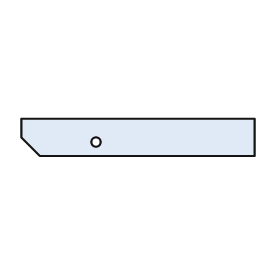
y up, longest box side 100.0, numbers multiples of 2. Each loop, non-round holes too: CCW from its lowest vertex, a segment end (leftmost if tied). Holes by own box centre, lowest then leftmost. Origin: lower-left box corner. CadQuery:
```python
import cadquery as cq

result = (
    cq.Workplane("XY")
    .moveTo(8.0, 0.0)
    .lineTo(100.0, 0.0)
    .lineTo(100.0, 16.0)
    .lineTo(0.0, 16.0)
    .lineTo(0.0, 8.0)
    .close()
    .moveTo(32.0, 6.0)
    .circle(2.0)
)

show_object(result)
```